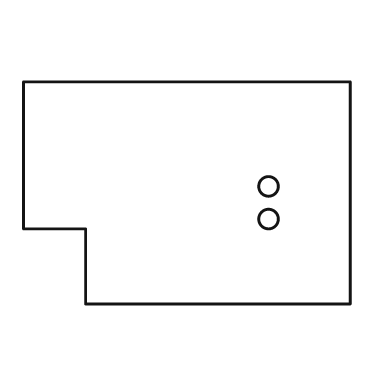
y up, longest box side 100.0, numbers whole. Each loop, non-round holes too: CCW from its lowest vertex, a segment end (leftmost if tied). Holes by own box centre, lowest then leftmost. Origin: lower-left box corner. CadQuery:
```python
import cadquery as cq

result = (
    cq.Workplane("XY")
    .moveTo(19.0, 0.0)
    .lineTo(100.0, 0.0)
    .lineTo(100.0, 68.0)
    .lineTo(0.0, 68.0)
    .lineTo(0.0, 23.0)
    .lineTo(19.0, 23.0)
    .close()
    .moveTo(75.0, 26.0)
    .circle(3.0)
    .moveTo(75.0, 36.0)
    .circle(3.0)
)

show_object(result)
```